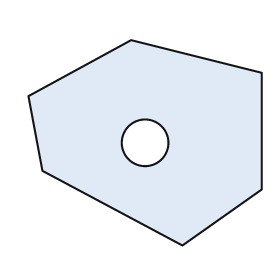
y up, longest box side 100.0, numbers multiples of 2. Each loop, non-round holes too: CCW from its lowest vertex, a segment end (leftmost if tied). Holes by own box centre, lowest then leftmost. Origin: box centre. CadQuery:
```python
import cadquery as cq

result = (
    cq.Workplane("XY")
    .moveTo(16.0, -44.0)
    .lineTo(50.0, -20.0)
    .lineTo(50.0, 30.0)
    .lineTo(-6.0, 44.0)
    .lineTo(-50.0, 20.0)
    .lineTo(-44.0, -12.0)
    .close()
    .moveTo(0.0, 0.0)
    .circle(10.0)
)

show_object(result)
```